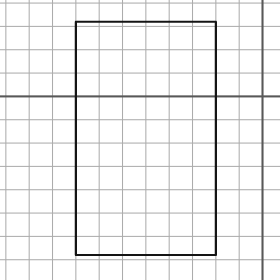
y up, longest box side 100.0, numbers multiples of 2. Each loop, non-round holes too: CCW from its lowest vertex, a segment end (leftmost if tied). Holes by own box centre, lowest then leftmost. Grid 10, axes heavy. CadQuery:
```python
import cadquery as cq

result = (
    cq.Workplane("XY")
    .moveTo(-80.0, -68.0)
    .lineTo(-20.0, -68.0)
    .lineTo(-20.0, 32.0)
    .lineTo(-80.0, 32.0)
    .close()
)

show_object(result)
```